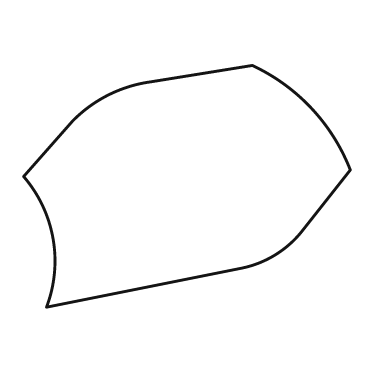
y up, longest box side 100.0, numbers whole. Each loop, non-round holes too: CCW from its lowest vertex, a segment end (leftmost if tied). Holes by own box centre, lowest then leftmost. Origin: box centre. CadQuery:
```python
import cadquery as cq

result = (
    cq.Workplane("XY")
    .moveTo(-43.0, -37.0)
    .lineTo(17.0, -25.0)
    .threePointArc((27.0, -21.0), (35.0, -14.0))
    .lineTo(50.0, 5.0)
    .threePointArc((38.0, 24.0), (20.0, 37.0))
    .lineTo(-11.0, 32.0)
    .threePointArc((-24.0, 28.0), (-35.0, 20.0))
    .lineTo(-50.0, 3.0)
    .threePointArc((-41.0, -16.0), (-43.0, -37.0))
    .close()
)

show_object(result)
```